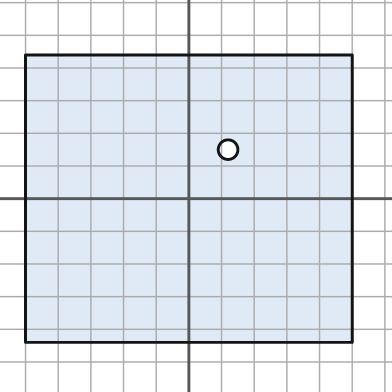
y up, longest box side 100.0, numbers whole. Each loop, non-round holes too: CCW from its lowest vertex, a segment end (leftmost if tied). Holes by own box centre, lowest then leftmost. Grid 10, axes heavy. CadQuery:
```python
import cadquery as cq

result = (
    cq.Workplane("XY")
    .moveTo(-50.0, -44.0)
    .lineTo(50.0, -44.0)
    .lineTo(50.0, 44.0)
    .lineTo(-50.0, 44.0)
    .close()
    .moveTo(12.0, 15.0)
    .circle(3.0)
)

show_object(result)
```